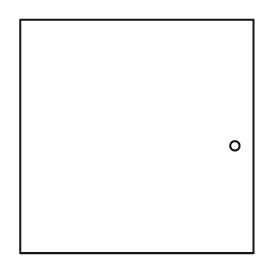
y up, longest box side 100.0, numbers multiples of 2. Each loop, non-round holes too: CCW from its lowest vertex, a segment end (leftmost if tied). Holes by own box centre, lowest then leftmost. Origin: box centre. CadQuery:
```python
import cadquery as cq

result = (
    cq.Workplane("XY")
    .moveTo(-50.0, -50.0)
    .lineTo(50.0, -50.0)
    .lineTo(50.0, 50.0)
    .lineTo(-50.0, 50.0)
    .close()
    .moveTo(42.0, -4.0)
    .circle(2.0)
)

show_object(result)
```